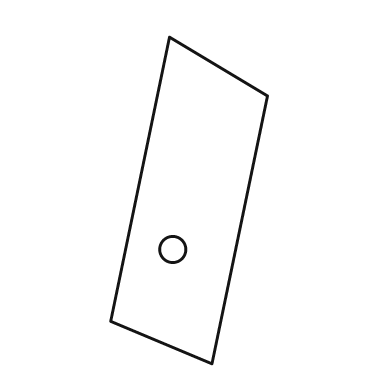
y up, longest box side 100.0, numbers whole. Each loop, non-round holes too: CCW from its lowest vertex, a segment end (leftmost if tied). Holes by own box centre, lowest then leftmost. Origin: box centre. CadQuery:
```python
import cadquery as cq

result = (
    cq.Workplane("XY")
    .moveTo(7.0, -50.0)
    .lineTo(24.0, 32.0)
    .lineTo(-6.0, 50.0)
    .lineTo(-24.0, -37.0)
    .close()
    .moveTo(-5.0, -15.0)
    .circle(4.0)
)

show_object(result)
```